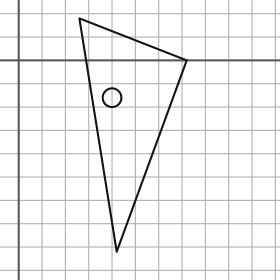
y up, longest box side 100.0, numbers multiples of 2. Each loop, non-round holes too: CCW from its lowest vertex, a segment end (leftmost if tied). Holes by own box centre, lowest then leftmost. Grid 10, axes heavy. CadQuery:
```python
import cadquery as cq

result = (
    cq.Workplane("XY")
    .moveTo(42.0, -82.0)
    .lineTo(72.0, 0.0)
    .lineTo(26.0, 18.0)
    .close()
    .moveTo(40.0, -16.0)
    .circle(4.0)
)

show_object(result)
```